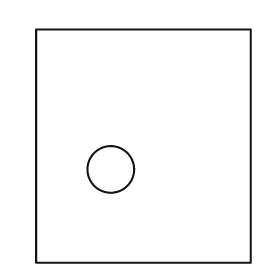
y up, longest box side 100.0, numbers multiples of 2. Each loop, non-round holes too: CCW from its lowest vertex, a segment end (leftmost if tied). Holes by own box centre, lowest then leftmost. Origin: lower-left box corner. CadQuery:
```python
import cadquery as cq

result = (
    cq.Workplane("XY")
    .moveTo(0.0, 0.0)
    .lineTo(92.0, 0.0)
    .lineTo(92.0, 100.0)
    .lineTo(0.0, 100.0)
    .close()
    .moveTo(32.0, 40.0)
    .circle(10.0)
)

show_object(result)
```